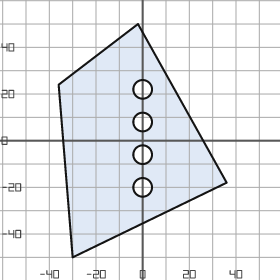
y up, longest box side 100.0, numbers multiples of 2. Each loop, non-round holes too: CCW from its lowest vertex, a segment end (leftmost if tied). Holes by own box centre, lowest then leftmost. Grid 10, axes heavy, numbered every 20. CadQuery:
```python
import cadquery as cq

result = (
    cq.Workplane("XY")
    .moveTo(-30.0, -50.0)
    .lineTo(36.0, -18.0)
    .lineTo(-2.0, 50.0)
    .lineTo(-36.0, 24.0)
    .close()
    .moveTo(0.0, -20.0)
    .circle(4.0)
    .moveTo(0.0, -6.0)
    .circle(4.0)
    .moveTo(0.0, 8.0)
    .circle(4.0)
    .moveTo(0.0, 22.0)
    .circle(4.0)
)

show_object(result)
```